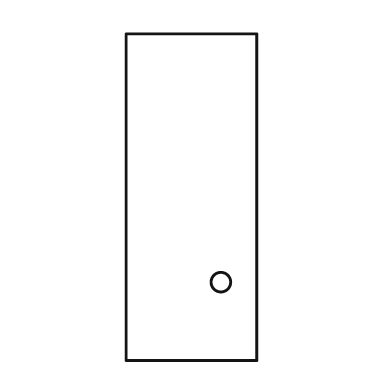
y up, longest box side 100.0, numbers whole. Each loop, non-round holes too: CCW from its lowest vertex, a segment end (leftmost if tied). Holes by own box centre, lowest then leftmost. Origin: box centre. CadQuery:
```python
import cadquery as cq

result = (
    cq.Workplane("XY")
    .moveTo(-20.0, -50.0)
    .lineTo(20.0, -50.0)
    .lineTo(20.0, 50.0)
    .lineTo(-20.0, 50.0)
    .close()
    .moveTo(9.0, -26.0)
    .circle(3.0)
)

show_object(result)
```